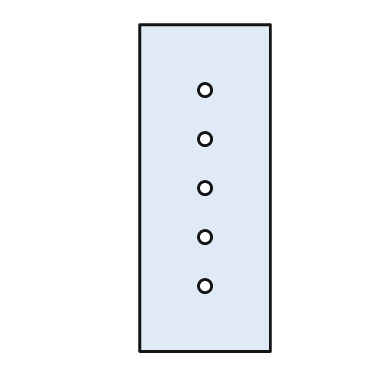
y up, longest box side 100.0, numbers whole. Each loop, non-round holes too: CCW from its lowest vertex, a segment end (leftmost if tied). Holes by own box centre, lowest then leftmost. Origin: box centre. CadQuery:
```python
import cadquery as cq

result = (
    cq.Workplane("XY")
    .moveTo(-20.0, -50.0)
    .lineTo(20.0, -50.0)
    .lineTo(20.0, 50.0)
    .lineTo(-20.0, 50.0)
    .close()
    .moveTo(0.0, -30.0)
    .circle(2.0)
    .moveTo(0.0, -15.0)
    .circle(2.0)
    .moveTo(0.0, 0.0)
    .circle(2.0)
    .moveTo(0.0, 15.0)
    .circle(2.0)
    .moveTo(0.0, 30.0)
    .circle(2.0)
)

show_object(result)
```